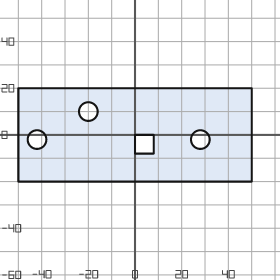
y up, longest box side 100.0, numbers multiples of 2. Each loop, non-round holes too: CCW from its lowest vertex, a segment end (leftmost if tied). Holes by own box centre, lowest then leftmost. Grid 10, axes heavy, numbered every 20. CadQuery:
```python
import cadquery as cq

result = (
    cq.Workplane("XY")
    .moveTo(-50.0, -20.0)
    .lineTo(50.0, -20.0)
    .lineTo(50.0, 20.0)
    .lineTo(-50.0, 20.0)
    .close()
    .moveTo(0.0, -8.0)
    .lineTo(8.0, -8.0)
    .lineTo(8.0, 0.0)
    .lineTo(0.0, 0.0)
    .close()
    .moveTo(-42.0, -2.0)
    .circle(4.0)
    .moveTo(28.0, -2.0)
    .circle(4.0)
    .moveTo(-20.0, 10.0)
    .circle(4.0)
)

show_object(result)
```